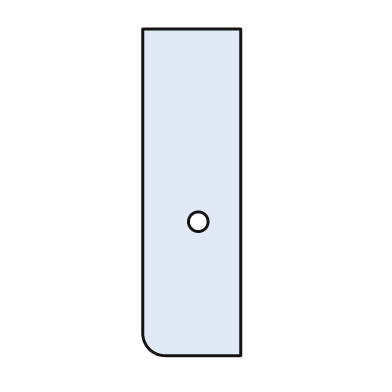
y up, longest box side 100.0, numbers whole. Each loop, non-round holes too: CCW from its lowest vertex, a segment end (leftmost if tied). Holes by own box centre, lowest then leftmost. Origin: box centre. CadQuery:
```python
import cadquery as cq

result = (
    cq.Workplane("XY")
    .moveTo(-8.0, -50.0)
    .lineTo(15.0, -50.0)
    .lineTo(15.0, 50.0)
    .lineTo(-15.0, 50.0)
    .lineTo(-15.0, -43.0)
    .threePointArc((-13.0, -48.0), (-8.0, -50.0))
    .close()
    .moveTo(2.0, -9.0)
    .circle(3.0)
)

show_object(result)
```